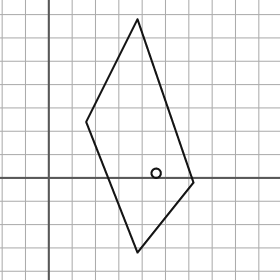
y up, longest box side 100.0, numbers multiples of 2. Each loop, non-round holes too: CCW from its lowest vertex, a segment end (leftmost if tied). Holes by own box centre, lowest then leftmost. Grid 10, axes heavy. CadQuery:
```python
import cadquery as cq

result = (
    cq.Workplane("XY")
    .moveTo(38.0, -32.0)
    .lineTo(62.0, -2.0)
    .lineTo(38.0, 68.0)
    .lineTo(16.0, 24.0)
    .close()
    .moveTo(46.0, 2.0)
    .circle(2.0)
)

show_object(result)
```